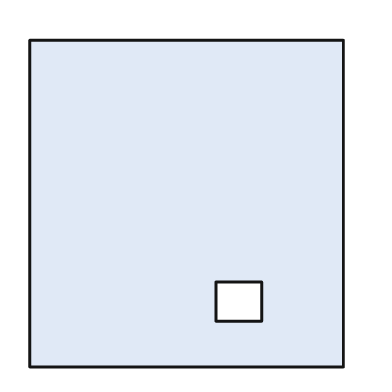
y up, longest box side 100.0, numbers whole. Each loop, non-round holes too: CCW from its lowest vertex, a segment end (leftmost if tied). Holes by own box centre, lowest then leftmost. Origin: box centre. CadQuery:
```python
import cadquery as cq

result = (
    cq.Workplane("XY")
    .moveTo(-48.0, -50.0)
    .lineTo(48.0, -50.0)
    .lineTo(48.0, 50.0)
    .lineTo(-48.0, 50.0)
    .close()
    .moveTo(9.0, -36.0)
    .lineTo(23.0, -36.0)
    .lineTo(23.0, -24.0)
    .lineTo(9.0, -24.0)
    .close()
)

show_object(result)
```